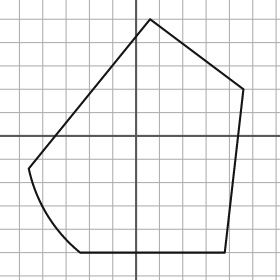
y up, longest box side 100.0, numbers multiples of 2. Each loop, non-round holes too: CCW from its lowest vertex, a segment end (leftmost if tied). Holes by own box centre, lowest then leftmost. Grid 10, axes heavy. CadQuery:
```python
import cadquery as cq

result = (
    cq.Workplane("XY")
    .moveTo(-24.0, -50.0)
    .lineTo(38.0, -50.0)
    .lineTo(46.0, 20.0)
    .lineTo(6.0, 50.0)
    .lineTo(-46.0, -14.0)
    .threePointArc((-38.0, -34.0), (-24.0, -50.0))
    .close()
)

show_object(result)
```